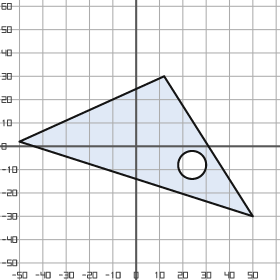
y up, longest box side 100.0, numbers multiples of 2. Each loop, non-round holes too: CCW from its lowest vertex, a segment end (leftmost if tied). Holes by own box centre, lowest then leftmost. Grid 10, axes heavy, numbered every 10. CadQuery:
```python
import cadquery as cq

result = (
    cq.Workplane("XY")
    .moveTo(50.0, -30.0)
    .lineTo(12.0, 30.0)
    .lineTo(-50.0, 2.0)
    .close()
    .moveTo(24.0, -8.0)
    .circle(6.0)
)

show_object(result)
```